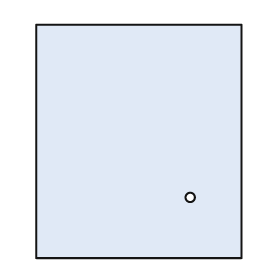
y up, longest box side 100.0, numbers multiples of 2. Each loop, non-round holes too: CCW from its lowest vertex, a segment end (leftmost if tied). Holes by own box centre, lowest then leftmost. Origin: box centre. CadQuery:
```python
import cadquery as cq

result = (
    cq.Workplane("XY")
    .moveTo(-44.0, -50.0)
    .lineTo(44.0, -50.0)
    .lineTo(44.0, 50.0)
    .lineTo(-44.0, 50.0)
    .close()
    .moveTo(22.0, -24.0)
    .circle(2.0)
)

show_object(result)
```